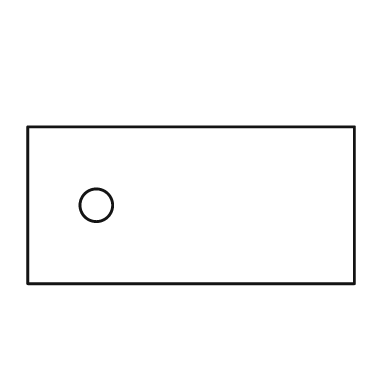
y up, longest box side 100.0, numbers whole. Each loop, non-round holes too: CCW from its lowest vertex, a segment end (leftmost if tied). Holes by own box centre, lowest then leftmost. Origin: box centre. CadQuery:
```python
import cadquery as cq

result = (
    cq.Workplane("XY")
    .moveTo(-50.0, -24.0)
    .lineTo(50.0, -24.0)
    .lineTo(50.0, 24.0)
    .lineTo(-50.0, 24.0)
    .close()
    .moveTo(-29.0, 0.0)
    .circle(5.0)
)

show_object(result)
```